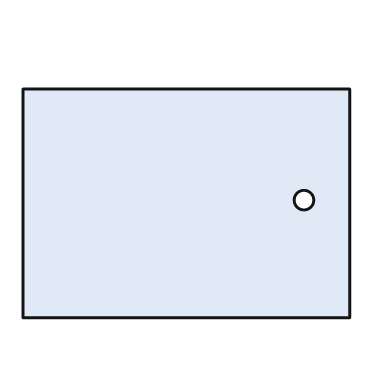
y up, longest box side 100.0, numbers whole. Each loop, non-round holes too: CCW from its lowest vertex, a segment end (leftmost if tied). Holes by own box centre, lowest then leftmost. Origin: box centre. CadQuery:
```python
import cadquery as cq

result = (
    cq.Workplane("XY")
    .moveTo(-50.0, -35.0)
    .lineTo(50.0, -35.0)
    .lineTo(50.0, 35.0)
    .lineTo(-50.0, 35.0)
    .close()
    .moveTo(36.0, 1.0)
    .circle(3.0)
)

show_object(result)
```